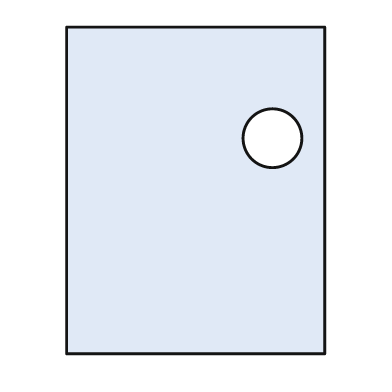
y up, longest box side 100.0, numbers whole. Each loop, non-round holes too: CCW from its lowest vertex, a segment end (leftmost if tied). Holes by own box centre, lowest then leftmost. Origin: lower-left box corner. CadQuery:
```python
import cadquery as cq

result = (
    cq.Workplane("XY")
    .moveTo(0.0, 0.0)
    .lineTo(79.0, 0.0)
    .lineTo(79.0, 100.0)
    .lineTo(0.0, 100.0)
    .close()
    .moveTo(63.0, 66.0)
    .circle(9.0)
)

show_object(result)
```